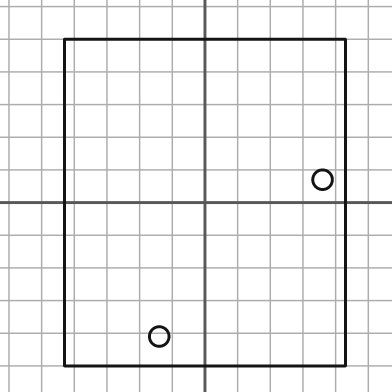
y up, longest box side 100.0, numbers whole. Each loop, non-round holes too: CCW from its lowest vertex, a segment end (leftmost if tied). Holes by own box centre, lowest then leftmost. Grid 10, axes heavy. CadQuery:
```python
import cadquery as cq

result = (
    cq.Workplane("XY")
    .moveTo(-43.0, -50.0)
    .lineTo(43.0, -50.0)
    .lineTo(43.0, 50.0)
    .lineTo(-43.0, 50.0)
    .close()
    .moveTo(-14.0, -41.0)
    .circle(3.0)
    .moveTo(36.0, 7.0)
    .circle(3.0)
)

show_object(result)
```